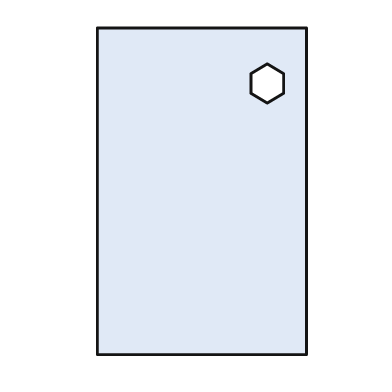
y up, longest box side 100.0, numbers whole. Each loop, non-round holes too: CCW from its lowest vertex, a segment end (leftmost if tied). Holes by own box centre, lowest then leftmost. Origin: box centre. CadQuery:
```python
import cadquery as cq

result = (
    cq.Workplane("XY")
    .moveTo(-32.0, -50.0)
    .lineTo(32.0, -50.0)
    .lineTo(32.0, 50.0)
    .lineTo(-32.0, 50.0)
    .close()
    .moveTo(20.0, 27.0)
    .lineTo(25.0, 30.0)
    .lineTo(25.0, 36.0)
    .lineTo(20.0, 39.0)
    .lineTo(15.0, 36.0)
    .lineTo(15.0, 30.0)
    .close()
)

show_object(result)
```